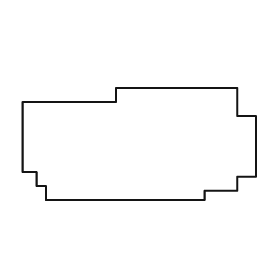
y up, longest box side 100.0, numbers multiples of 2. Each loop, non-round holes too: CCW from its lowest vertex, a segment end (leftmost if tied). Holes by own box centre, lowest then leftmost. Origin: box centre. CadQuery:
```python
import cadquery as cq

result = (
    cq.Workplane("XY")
    .moveTo(-40.0, -24.0)
    .lineTo(28.0, -24.0)
    .lineTo(28.0, -20.0)
    .lineTo(42.0, -20.0)
    .lineTo(42.0, -14.0)
    .lineTo(50.0, -14.0)
    .lineTo(50.0, 12.0)
    .lineTo(42.0, 12.0)
    .lineTo(42.0, 24.0)
    .lineTo(-10.0, 24.0)
    .lineTo(-10.0, 18.0)
    .lineTo(-50.0, 18.0)
    .lineTo(-50.0, -12.0)
    .lineTo(-44.0, -12.0)
    .lineTo(-44.0, -18.0)
    .lineTo(-40.0, -18.0)
    .close()
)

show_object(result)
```